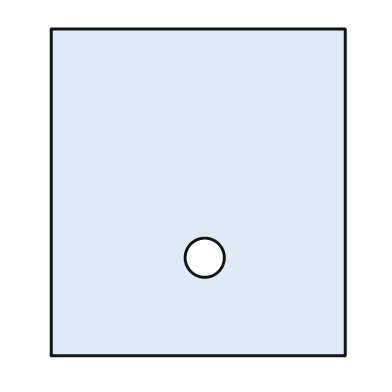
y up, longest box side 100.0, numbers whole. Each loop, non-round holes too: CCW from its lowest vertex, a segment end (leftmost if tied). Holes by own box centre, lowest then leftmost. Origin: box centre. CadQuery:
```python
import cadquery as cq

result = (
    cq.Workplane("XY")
    .moveTo(-45.0, -50.0)
    .lineTo(45.0, -50.0)
    .lineTo(45.0, 50.0)
    .lineTo(-45.0, 50.0)
    .close()
    .moveTo(2.0, -20.0)
    .circle(6.0)
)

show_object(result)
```